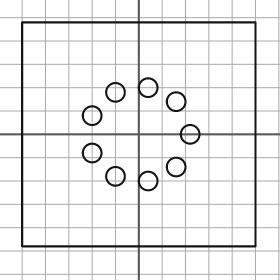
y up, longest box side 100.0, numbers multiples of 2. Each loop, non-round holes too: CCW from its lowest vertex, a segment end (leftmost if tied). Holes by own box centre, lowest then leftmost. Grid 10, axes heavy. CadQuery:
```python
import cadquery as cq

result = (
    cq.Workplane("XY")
    .moveTo(-50.0, -48.0)
    .lineTo(50.0, -48.0)
    .lineTo(50.0, 48.0)
    .lineTo(-50.0, 48.0)
    .close()
    .moveTo(4.0, -20.0)
    .circle(4.0)
    .moveTo(-10.0, -18.0)
    .circle(4.0)
    .moveTo(16.0, -14.0)
    .circle(4.0)
    .moveTo(-20.0, -8.0)
    .circle(4.0)
    .moveTo(22.0, 0.0)
    .circle(4.0)
    .moveTo(-20.0, 8.0)
    .circle(4.0)
    .moveTo(16.0, 14.0)
    .circle(4.0)
    .moveTo(-10.0, 18.0)
    .circle(4.0)
    .moveTo(4.0, 20.0)
    .circle(4.0)
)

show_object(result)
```